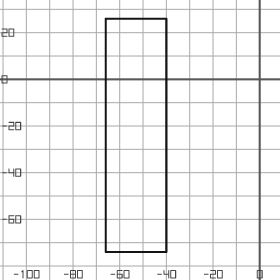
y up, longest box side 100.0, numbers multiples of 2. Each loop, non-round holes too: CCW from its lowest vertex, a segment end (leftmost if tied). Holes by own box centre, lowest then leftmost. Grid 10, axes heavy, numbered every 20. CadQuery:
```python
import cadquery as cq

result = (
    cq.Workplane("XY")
    .moveTo(-66.0, -74.0)
    .lineTo(-40.0, -74.0)
    .lineTo(-40.0, 26.0)
    .lineTo(-66.0, 26.0)
    .close()
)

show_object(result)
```